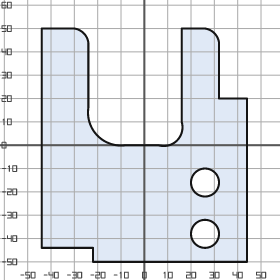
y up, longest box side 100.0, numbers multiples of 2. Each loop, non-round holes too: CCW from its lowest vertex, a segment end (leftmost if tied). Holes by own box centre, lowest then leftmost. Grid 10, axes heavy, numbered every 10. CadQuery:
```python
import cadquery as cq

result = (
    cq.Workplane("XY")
    .moveTo(-22.0, -50.0)
    .lineTo(44.0, -50.0)
    .lineTo(44.0, 20.0)
    .lineTo(32.0, 20.0)
    .lineTo(32.0, 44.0)
    .threePointArc((30.0, 48.0), (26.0, 50.0))
    .lineTo(16.0, 50.0)
    .lineTo(16.0, 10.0)
    .threePointArc((14.0, 2.0), (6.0, 0.0))
    .lineTo(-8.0, 0.0)
    .threePointArc((-20.0, 4.0), (-24.0, 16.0))
    .lineTo(-24.0, 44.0)
    .threePointArc((-26.0, 48.0), (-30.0, 50.0))
    .lineTo(-44.0, 50.0)
    .lineTo(-44.0, -44.0)
    .lineTo(-22.0, -44.0)
    .close()
    .moveTo(26.0, -38.0)
    .circle(6.0)
    .moveTo(26.0, -16.0)
    .circle(6.0)
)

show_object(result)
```